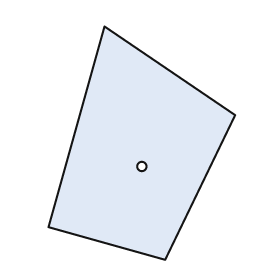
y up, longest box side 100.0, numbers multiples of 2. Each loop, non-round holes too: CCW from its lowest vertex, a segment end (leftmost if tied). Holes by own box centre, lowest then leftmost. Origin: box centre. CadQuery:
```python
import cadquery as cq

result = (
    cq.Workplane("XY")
    .moveTo(10.0, -50.0)
    .lineTo(40.0, 12.0)
    .lineTo(-16.0, 50.0)
    .lineTo(-40.0, -36.0)
    .close()
    .moveTo(0.0, -10.0)
    .circle(2.0)
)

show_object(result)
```